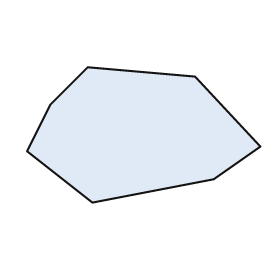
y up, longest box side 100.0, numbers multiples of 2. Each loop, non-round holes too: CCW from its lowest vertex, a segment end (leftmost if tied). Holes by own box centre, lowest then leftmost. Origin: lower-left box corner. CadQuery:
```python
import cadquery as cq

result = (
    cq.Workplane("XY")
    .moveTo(28.0, 0.0)
    .lineTo(80.0, 10.0)
    .lineTo(100.0, 24.0)
    .lineTo(72.0, 54.0)
    .lineTo(26.0, 58.0)
    .lineTo(10.0, 42.0)
    .lineTo(0.0, 22.0)
    .close()
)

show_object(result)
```